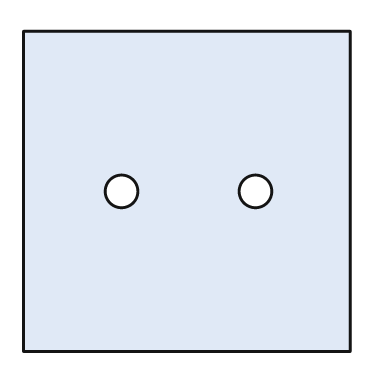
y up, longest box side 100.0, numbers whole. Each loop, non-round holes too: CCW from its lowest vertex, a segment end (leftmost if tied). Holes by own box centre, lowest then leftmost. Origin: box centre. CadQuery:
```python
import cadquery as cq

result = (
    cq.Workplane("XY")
    .moveTo(-50.0, -49.0)
    .lineTo(50.0, -49.0)
    .lineTo(50.0, 49.0)
    .lineTo(-50.0, 49.0)
    .close()
    .moveTo(-20.0, 0.0)
    .circle(5.0)
    .moveTo(21.0, 0.0)
    .circle(5.0)
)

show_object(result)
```